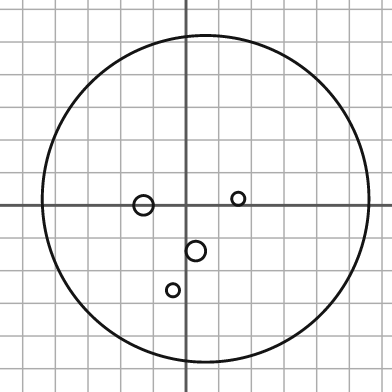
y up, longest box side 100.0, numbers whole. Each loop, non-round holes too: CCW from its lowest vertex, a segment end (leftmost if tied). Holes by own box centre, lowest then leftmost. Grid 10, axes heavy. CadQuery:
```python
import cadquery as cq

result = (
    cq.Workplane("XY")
    .moveTo(6.0, 2.0)
    .circle(50.0)
    .moveTo(-4.0, -26.0)
    .circle(2.0)
    .moveTo(3.0, -14.0)
    .circle(3.0)
    .moveTo(-13.0, 0.0)
    .circle(3.0)
    .moveTo(16.0, 2.0)
    .circle(2.0)
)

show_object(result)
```